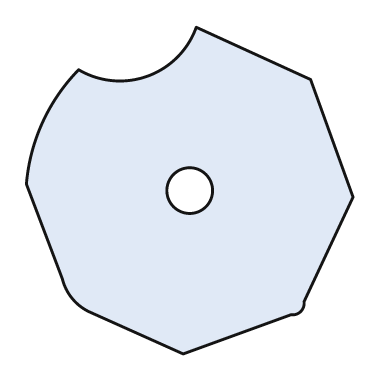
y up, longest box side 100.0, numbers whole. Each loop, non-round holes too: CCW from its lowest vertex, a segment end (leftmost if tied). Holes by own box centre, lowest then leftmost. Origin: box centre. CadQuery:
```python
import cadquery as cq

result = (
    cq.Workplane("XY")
    .moveTo(-2.0, -50.0)
    .lineTo(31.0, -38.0)
    .threePointArc((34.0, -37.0), (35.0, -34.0))
    .lineTo(50.0, -2.0)
    .lineTo(37.0, 34.0)
    .lineTo(2.0, 50.0)
    .threePointArc((-13.0, 35.0), (-34.0, 37.0))
    .threePointArc((-45.0, 21.0), (-50.0, 2.0))
    .lineTo(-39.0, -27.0)
    .threePointArc((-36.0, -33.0), (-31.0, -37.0))
    .close()
    .moveTo(0.0, 0.0)
    .circle(7.0)
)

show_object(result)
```